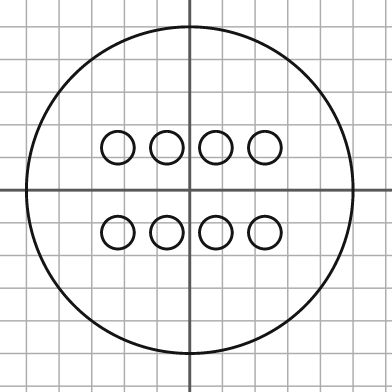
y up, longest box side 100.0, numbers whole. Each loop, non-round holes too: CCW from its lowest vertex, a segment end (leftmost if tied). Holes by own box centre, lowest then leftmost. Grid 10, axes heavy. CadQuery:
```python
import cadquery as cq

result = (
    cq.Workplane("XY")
    .moveTo(0.0, 0.0)
    .circle(50.0)
    .moveTo(-22.0, -13.0)
    .circle(5.0)
    .moveTo(-7.0, -13.0)
    .circle(5.0)
    .moveTo(8.0, -13.0)
    .circle(5.0)
    .moveTo(23.0, -13.0)
    .circle(5.0)
    .moveTo(-22.0, 13.0)
    .circle(5.0)
    .moveTo(-7.0, 13.0)
    .circle(5.0)
    .moveTo(8.0, 13.0)
    .circle(5.0)
    .moveTo(23.0, 13.0)
    .circle(5.0)
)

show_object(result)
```